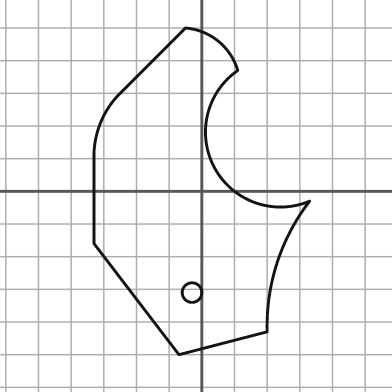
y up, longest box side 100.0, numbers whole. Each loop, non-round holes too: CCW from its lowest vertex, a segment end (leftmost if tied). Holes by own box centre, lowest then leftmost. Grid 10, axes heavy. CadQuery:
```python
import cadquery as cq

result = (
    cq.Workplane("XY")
    .moveTo(-7.0, -50.0)
    .lineTo(20.0, -43.0)
    .threePointArc((23.0, -22.0), (33.0, -3.0))
    .threePointArc((4.0, 7.0), (11.0, 37.0))
    .threePointArc((5.0, 46.0), (-5.0, 50.0))
    .lineTo(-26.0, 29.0)
    .threePointArc((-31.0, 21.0), (-33.0, 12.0))
    .lineTo(-33.0, -16.0)
    .close()
    .moveTo(-3.0, -31.0)
    .circle(3.0)
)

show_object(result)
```